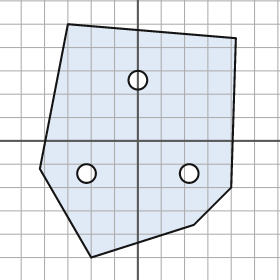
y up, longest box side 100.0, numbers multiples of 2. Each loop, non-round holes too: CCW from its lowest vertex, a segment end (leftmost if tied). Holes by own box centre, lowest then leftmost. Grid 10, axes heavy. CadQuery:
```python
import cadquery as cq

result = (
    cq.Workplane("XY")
    .moveTo(-20.0, -50.0)
    .lineTo(24.0, -36.0)
    .lineTo(40.0, -20.0)
    .lineTo(42.0, 44.0)
    .lineTo(-30.0, 50.0)
    .lineTo(-42.0, -12.0)
    .close()
    .moveTo(-22.0, -14.0)
    .circle(4.0)
    .moveTo(22.0, -14.0)
    .circle(4.0)
    .moveTo(0.0, 26.0)
    .circle(4.0)
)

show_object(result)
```